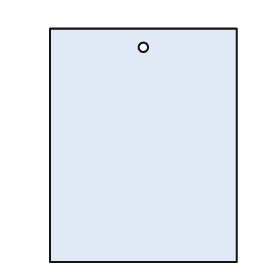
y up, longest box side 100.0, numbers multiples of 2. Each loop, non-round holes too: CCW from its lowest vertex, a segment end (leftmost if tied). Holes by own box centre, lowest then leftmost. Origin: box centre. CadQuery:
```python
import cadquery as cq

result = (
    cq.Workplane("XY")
    .moveTo(-40.0, -50.0)
    .lineTo(40.0, -50.0)
    .lineTo(40.0, 50.0)
    .lineTo(-40.0, 50.0)
    .close()
    .moveTo(0.0, 42.0)
    .circle(2.0)
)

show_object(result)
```